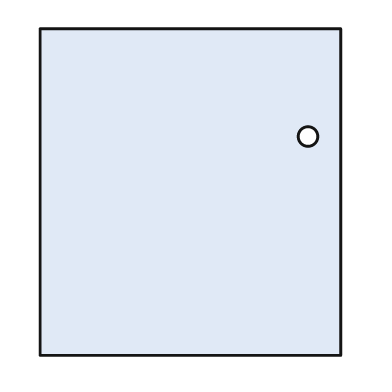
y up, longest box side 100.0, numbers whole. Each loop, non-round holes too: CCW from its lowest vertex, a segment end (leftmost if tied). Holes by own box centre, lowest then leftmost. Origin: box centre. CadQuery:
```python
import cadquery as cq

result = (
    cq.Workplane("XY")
    .moveTo(-46.0, -50.0)
    .lineTo(46.0, -50.0)
    .lineTo(46.0, 50.0)
    .lineTo(-46.0, 50.0)
    .close()
    .moveTo(36.0, 17.0)
    .circle(3.0)
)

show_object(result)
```